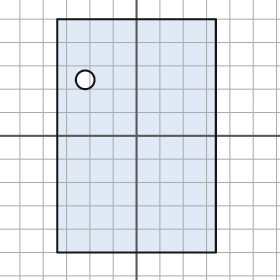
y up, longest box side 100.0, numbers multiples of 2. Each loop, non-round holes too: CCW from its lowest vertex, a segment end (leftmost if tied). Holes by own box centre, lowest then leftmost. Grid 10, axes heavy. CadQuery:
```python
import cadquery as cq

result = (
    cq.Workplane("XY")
    .moveTo(-34.0, -50.0)
    .lineTo(34.0, -50.0)
    .lineTo(34.0, 50.0)
    .lineTo(-34.0, 50.0)
    .close()
    .moveTo(-22.0, 24.0)
    .circle(4.0)
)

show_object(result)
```